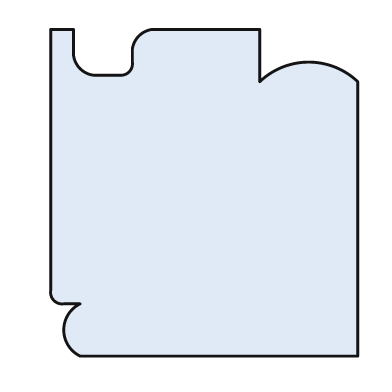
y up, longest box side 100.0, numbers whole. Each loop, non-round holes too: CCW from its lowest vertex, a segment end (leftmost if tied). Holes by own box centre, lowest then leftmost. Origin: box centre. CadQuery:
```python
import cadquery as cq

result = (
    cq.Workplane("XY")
    .moveTo(-38.0, -50.0)
    .lineTo(47.0, -50.0)
    .lineTo(47.0, 34.0)
    .threePointArc((32.0, 40.0), (17.0, 34.0))
    .lineTo(17.0, 50.0)
    .lineTo(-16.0, 50.0)
    .threePointArc((-20.0, 48.0), (-22.0, 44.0))
    .lineTo(-22.0, 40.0)
    .threePointArc((-23.0, 37.0), (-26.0, 36.0))
    .lineTo(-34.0, 36.0)
    .threePointArc((-38.0, 38.0), (-40.0, 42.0))
    .lineTo(-40.0, 50.0)
    .lineTo(-47.0, 50.0)
    .lineTo(-47.0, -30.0)
    .threePointArc((-46.0, -33.0), (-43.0, -34.0))
    .lineTo(-38.0, -34.0)
    .threePointArc((-43.0, -42.0), (-38.0, -50.0))
    .close()
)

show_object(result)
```